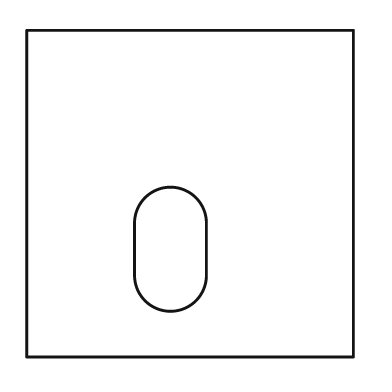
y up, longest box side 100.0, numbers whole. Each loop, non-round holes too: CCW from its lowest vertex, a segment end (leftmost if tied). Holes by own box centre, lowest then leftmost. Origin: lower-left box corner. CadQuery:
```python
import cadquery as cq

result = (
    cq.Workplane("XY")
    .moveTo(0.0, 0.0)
    .lineTo(100.0, 0.0)
    .lineTo(100.0, 100.0)
    .lineTo(0.0, 100.0)
    .close()
    .moveTo(33.0, 25.0)
    .threePointArc((44.0, 14.0), (55.0, 25.0))
    .lineTo(55.0, 41.0)
    .threePointArc((44.0, 52.0), (33.0, 41.0))
    .close()
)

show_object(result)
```